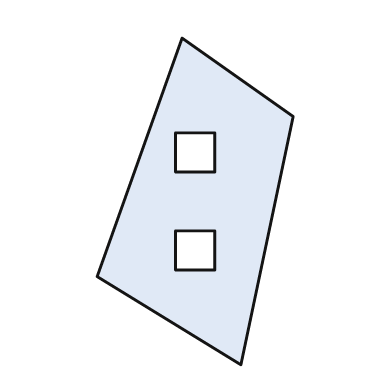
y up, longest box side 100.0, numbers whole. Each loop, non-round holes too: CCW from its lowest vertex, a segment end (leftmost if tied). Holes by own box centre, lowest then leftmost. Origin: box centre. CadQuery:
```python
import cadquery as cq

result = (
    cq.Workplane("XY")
    .moveTo(14.0, -50.0)
    .lineTo(30.0, 26.0)
    .lineTo(-4.0, 50.0)
    .lineTo(-30.0, -23.0)
    .close()
    .moveTo(-6.0, -21.0)
    .lineTo(6.0, -21.0)
    .lineTo(6.0, -9.0)
    .lineTo(-6.0, -9.0)
    .close()
    .moveTo(-6.0, 9.0)
    .lineTo(6.0, 9.0)
    .lineTo(6.0, 21.0)
    .lineTo(-6.0, 21.0)
    .close()
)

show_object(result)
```